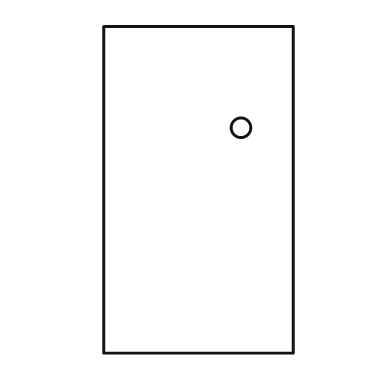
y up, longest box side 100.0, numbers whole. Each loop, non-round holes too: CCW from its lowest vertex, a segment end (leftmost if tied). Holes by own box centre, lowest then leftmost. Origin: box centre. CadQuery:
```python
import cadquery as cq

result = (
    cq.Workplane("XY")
    .moveTo(-29.0, -50.0)
    .lineTo(29.0, -50.0)
    .lineTo(29.0, 50.0)
    .lineTo(-29.0, 50.0)
    .close()
    .moveTo(13.0, 19.0)
    .circle(3.0)
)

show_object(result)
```